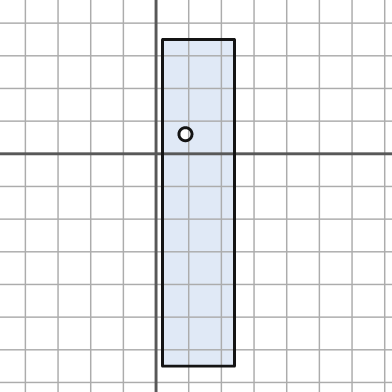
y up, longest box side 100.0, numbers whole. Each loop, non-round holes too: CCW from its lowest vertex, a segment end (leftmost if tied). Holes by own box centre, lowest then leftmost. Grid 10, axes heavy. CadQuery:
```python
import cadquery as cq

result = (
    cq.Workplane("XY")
    .moveTo(2.0, -65.0)
    .lineTo(24.0, -65.0)
    .lineTo(24.0, 35.0)
    .lineTo(2.0, 35.0)
    .close()
    .moveTo(9.0, 6.0)
    .circle(2.0)
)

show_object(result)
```